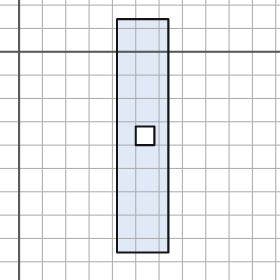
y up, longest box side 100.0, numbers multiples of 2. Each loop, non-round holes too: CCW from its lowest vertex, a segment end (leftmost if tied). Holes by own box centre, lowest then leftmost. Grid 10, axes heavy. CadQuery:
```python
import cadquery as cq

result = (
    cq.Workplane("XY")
    .moveTo(42.0, -86.0)
    .lineTo(64.0, -86.0)
    .lineTo(64.0, 14.0)
    .lineTo(42.0, 14.0)
    .close()
    .moveTo(50.0, -40.0)
    .lineTo(58.0, -40.0)
    .lineTo(58.0, -32.0)
    .lineTo(50.0, -32.0)
    .close()
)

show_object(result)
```